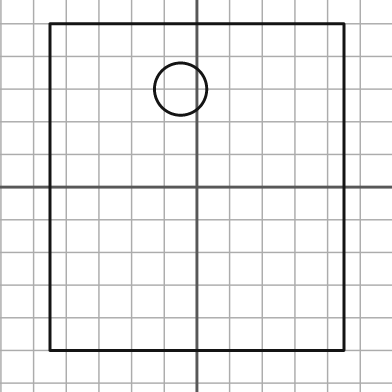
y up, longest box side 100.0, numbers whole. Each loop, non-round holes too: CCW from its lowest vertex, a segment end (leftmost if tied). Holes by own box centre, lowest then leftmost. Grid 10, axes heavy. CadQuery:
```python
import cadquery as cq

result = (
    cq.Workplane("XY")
    .moveTo(-45.0, -50.0)
    .lineTo(45.0, -50.0)
    .lineTo(45.0, 50.0)
    .lineTo(-45.0, 50.0)
    .close()
    .moveTo(-5.0, 30.0)
    .circle(8.0)
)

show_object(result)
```